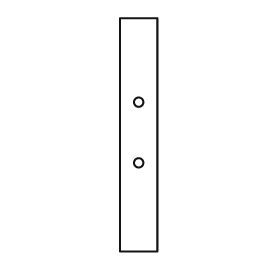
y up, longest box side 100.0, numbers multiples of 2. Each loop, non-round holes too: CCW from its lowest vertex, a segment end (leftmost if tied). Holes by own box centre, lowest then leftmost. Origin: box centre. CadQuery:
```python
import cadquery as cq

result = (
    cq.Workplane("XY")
    .moveTo(-8.0, -50.0)
    .lineTo(8.0, -50.0)
    .lineTo(8.0, 50.0)
    .lineTo(-8.0, 50.0)
    .close()
    .moveTo(0.0, -12.0)
    .circle(2.0)
    .moveTo(0.0, 14.0)
    .circle(2.0)
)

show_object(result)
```